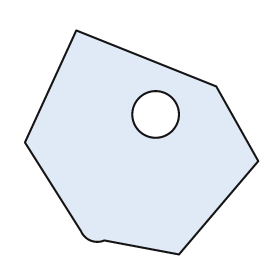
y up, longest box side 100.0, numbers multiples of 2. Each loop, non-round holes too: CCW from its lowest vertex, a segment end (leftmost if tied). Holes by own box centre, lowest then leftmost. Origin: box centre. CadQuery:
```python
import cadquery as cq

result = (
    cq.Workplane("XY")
    .moveTo(16.0, -48.0)
    .lineTo(50.0, -8.0)
    .lineTo(32.0, 24.0)
    .lineTo(-28.0, 48.0)
    .lineTo(-50.0, 0.0)
    .lineTo(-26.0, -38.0)
    .threePointArc((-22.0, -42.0), (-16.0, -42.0))
    .close()
    .moveTo(6.0, 12.0)
    .circle(10.0)
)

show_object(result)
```